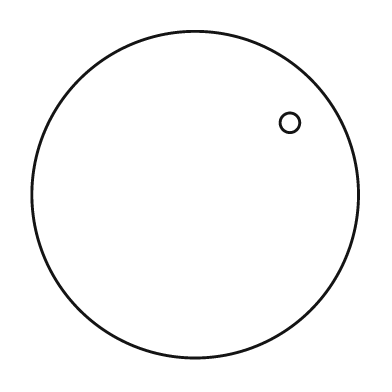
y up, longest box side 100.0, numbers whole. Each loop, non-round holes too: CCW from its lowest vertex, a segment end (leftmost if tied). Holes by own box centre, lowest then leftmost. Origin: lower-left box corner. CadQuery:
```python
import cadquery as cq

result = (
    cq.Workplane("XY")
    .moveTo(50.0, 50.0)
    .circle(50.0)
    .moveTo(79.0, 72.0)
    .circle(3.0)
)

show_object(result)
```